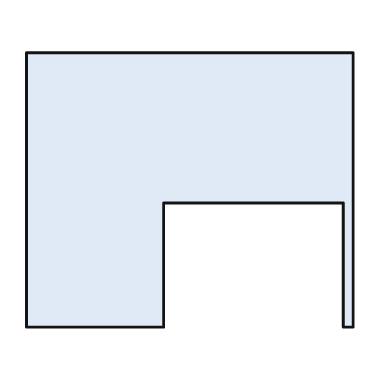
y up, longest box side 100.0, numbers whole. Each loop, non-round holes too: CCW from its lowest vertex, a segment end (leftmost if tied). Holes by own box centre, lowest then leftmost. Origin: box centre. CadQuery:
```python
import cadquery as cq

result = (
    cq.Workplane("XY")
    .moveTo(-50.0, -42.0)
    .lineTo(-8.0, -42.0)
    .lineTo(-8.0, -4.0)
    .lineTo(47.0, -4.0)
    .lineTo(47.0, -42.0)
    .lineTo(50.0, -42.0)
    .lineTo(50.0, 42.0)
    .lineTo(-50.0, 42.0)
    .close()
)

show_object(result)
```